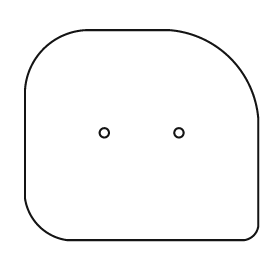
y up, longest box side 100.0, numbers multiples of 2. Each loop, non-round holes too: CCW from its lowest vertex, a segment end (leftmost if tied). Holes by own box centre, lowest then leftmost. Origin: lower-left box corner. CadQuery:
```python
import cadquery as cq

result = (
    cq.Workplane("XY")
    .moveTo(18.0, 0.0)
    .lineTo(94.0, 0.0)
    .threePointArc((98.0, 2.0), (100.0, 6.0))
    .lineTo(100.0, 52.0)
    .threePointArc((88.0, 78.0), (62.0, 90.0))
    .lineTo(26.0, 90.0)
    .threePointArc((8.0, 82.0), (0.0, 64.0))
    .lineTo(0.0, 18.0)
    .threePointArc((6.0, 6.0), (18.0, 0.0))
    .close()
    .moveTo(34.0, 46.0)
    .circle(2.0)
    .moveTo(66.0, 46.0)
    .circle(2.0)
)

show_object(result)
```